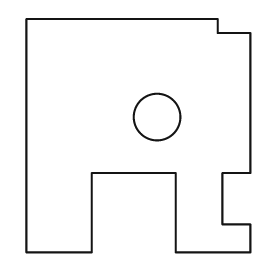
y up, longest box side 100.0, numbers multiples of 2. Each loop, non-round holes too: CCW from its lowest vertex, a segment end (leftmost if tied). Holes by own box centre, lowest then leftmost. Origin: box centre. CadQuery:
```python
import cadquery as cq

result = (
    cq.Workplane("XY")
    .moveTo(-48.0, -50.0)
    .lineTo(-20.0, -50.0)
    .lineTo(-20.0, -16.0)
    .lineTo(16.0, -16.0)
    .lineTo(16.0, -50.0)
    .lineTo(48.0, -50.0)
    .lineTo(48.0, -38.0)
    .lineTo(36.0, -38.0)
    .lineTo(36.0, -16.0)
    .lineTo(48.0, -16.0)
    .lineTo(48.0, 44.0)
    .lineTo(34.0, 44.0)
    .lineTo(34.0, 50.0)
    .lineTo(-48.0, 50.0)
    .close()
    .moveTo(8.0, 8.0)
    .circle(10.0)
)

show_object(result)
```